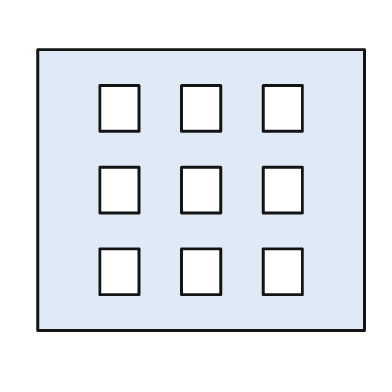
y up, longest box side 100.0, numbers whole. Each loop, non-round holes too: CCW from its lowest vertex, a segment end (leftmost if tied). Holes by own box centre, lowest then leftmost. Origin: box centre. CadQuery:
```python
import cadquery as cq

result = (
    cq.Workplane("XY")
    .moveTo(-50.0, -43.0)
    .lineTo(50.0, -43.0)
    .lineTo(50.0, 43.0)
    .lineTo(-50.0, 43.0)
    .close()
    .moveTo(-31.0, -32.0)
    .lineTo(-19.0, -32.0)
    .lineTo(-19.0, -18.0)
    .lineTo(-31.0, -18.0)
    .close()
    .moveTo(-6.0, -32.0)
    .lineTo(6.0, -32.0)
    .lineTo(6.0, -18.0)
    .lineTo(-6.0, -18.0)
    .close()
    .moveTo(19.0, -32.0)
    .lineTo(31.0, -32.0)
    .lineTo(31.0, -18.0)
    .lineTo(19.0, -18.0)
    .close()
    .moveTo(-31.0, -7.0)
    .lineTo(-19.0, -7.0)
    .lineTo(-19.0, 7.0)
    .lineTo(-31.0, 7.0)
    .close()
    .moveTo(-6.0, -7.0)
    .lineTo(6.0, -7.0)
    .lineTo(6.0, 7.0)
    .lineTo(-6.0, 7.0)
    .close()
    .moveTo(19.0, -7.0)
    .lineTo(31.0, -7.0)
    .lineTo(31.0, 7.0)
    .lineTo(19.0, 7.0)
    .close()
    .moveTo(-31.0, 18.0)
    .lineTo(-19.0, 18.0)
    .lineTo(-19.0, 32.0)
    .lineTo(-31.0, 32.0)
    .close()
    .moveTo(-6.0, 18.0)
    .lineTo(6.0, 18.0)
    .lineTo(6.0, 32.0)
    .lineTo(-6.0, 32.0)
    .close()
    .moveTo(19.0, 18.0)
    .lineTo(31.0, 18.0)
    .lineTo(31.0, 32.0)
    .lineTo(19.0, 32.0)
    .close()
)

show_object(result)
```